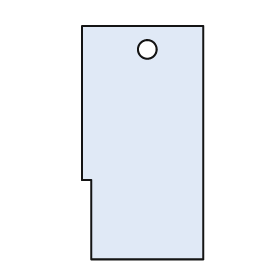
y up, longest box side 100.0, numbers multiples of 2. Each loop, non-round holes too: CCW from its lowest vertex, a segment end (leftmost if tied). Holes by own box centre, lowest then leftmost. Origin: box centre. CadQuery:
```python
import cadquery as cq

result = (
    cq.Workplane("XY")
    .moveTo(-22.0, -50.0)
    .lineTo(26.0, -50.0)
    .lineTo(26.0, 50.0)
    .lineTo(-26.0, 50.0)
    .lineTo(-26.0, -16.0)
    .lineTo(-22.0, -16.0)
    .close()
    .moveTo(2.0, 40.0)
    .circle(4.0)
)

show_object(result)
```